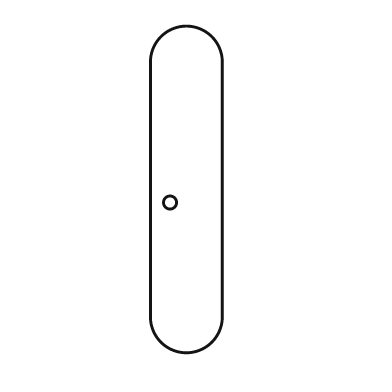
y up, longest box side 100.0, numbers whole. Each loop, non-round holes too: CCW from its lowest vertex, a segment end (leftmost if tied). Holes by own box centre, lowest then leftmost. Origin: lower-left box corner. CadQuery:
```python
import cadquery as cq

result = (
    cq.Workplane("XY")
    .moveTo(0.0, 11.0)
    .threePointArc((11.0, 0.0), (22.0, 11.0))
    .lineTo(22.0, 89.0)
    .threePointArc((11.0, 100.0), (0.0, 89.0))
    .close()
    .moveTo(6.0, 46.0)
    .circle(2.0)
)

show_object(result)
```